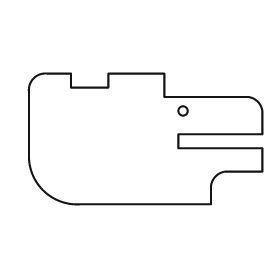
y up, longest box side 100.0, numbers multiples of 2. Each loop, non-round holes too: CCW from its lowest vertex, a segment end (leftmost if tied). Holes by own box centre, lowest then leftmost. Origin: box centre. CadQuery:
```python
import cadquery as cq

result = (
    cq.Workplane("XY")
    .moveTo(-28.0, -28.0)
    .lineTo(28.0, -28.0)
    .lineTo(28.0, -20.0)
    .threePointArc((30.0, -16.0), (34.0, -14.0))
    .lineTo(50.0, -14.0)
    .lineTo(50.0, -4.0)
    .lineTo(14.0, -4.0)
    .lineTo(14.0, 2.0)
    .lineTo(50.0, 2.0)
    .lineTo(50.0, 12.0)
    .threePointArc((48.0, 16.0), (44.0, 18.0))
    .lineTo(8.0, 18.0)
    .lineTo(8.0, 28.0)
    .lineTo(-16.0, 28.0)
    .lineTo(-16.0, 22.0)
    .lineTo(-32.0, 22.0)
    .lineTo(-32.0, 28.0)
    .lineTo(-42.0, 28.0)
    .threePointArc((-48.0, 26.0), (-50.0, 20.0))
    .lineTo(-50.0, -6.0)
    .threePointArc((-44.0, -22.0), (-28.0, -28.0))
    .close()
    .moveTo(16.0, 12.0)
    .circle(2.0)
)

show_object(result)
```